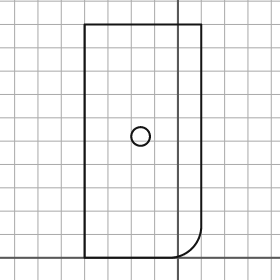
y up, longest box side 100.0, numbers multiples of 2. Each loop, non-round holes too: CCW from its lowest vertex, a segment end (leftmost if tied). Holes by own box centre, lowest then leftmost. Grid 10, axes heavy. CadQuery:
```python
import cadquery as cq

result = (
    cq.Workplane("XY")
    .moveTo(-40.0, 0.0)
    .lineTo(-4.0, 0.0)
    .threePointArc((6.0, 4.0), (10.0, 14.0))
    .lineTo(10.0, 100.0)
    .lineTo(-40.0, 100.0)
    .close()
    .moveTo(-16.0, 52.0)
    .circle(4.0)
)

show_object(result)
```